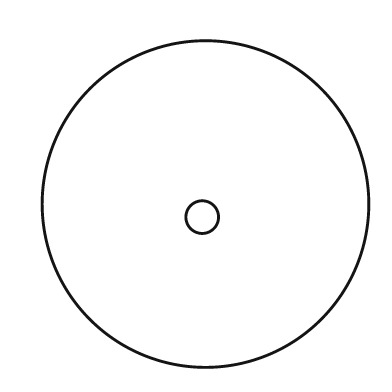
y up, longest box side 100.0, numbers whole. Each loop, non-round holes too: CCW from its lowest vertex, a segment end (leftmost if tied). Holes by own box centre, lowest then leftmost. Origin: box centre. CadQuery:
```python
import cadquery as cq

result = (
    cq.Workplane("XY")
    .moveTo(0.0, 0.0)
    .circle(50.0)
    .moveTo(-1.0, -4.0)
    .circle(5.0)
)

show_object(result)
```